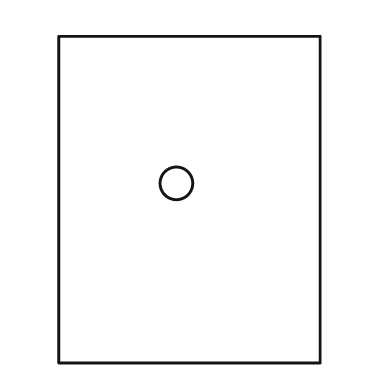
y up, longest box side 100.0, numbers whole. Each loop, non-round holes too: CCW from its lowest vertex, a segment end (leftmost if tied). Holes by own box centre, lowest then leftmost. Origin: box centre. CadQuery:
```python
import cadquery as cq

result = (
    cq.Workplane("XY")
    .moveTo(-40.0, -50.0)
    .lineTo(40.0, -50.0)
    .lineTo(40.0, 50.0)
    .lineTo(-40.0, 50.0)
    .close()
    .moveTo(-4.0, 5.0)
    .circle(5.0)
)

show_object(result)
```